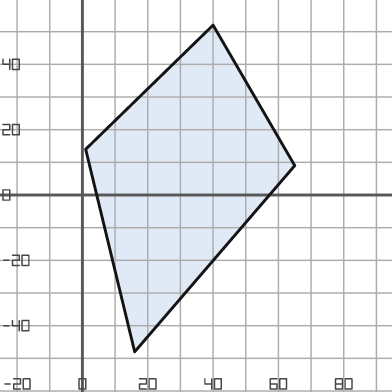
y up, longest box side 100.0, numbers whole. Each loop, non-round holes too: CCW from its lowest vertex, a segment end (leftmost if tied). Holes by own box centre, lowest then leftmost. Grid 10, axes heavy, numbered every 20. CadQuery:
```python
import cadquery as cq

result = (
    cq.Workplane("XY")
    .moveTo(16.0, -48.0)
    .lineTo(65.0, 9.0)
    .lineTo(40.0, 52.0)
    .lineTo(1.0, 14.0)
    .close()
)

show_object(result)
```